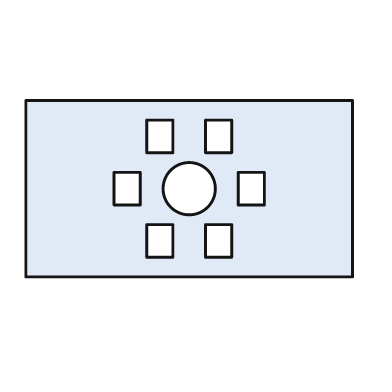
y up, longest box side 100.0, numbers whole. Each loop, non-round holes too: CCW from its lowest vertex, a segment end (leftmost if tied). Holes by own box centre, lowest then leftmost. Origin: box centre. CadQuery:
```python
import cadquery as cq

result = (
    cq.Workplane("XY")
    .moveTo(-50.0, -27.0)
    .lineTo(50.0, -27.0)
    .lineTo(50.0, 27.0)
    .lineTo(-50.0, 27.0)
    .close()
    .moveTo(-13.0, -21.0)
    .lineTo(-5.0, -21.0)
    .lineTo(-5.0, -11.0)
    .lineTo(-13.0, -11.0)
    .close()
    .moveTo(5.0, -21.0)
    .lineTo(13.0, -21.0)
    .lineTo(13.0, -11.0)
    .lineTo(5.0, -11.0)
    .close()
    .moveTo(-23.0, -5.0)
    .lineTo(-15.0, -5.0)
    .lineTo(-15.0, 5.0)
    .lineTo(-23.0, 5.0)
    .close()
    .moveTo(0.0, 0.0)
    .circle(8.0)
    .moveTo(15.0, -5.0)
    .lineTo(23.0, -5.0)
    .lineTo(23.0, 5.0)
    .lineTo(15.0, 5.0)
    .close()
    .moveTo(-13.0, 11.0)
    .lineTo(-5.0, 11.0)
    .lineTo(-5.0, 21.0)
    .lineTo(-13.0, 21.0)
    .close()
    .moveTo(5.0, 11.0)
    .lineTo(13.0, 11.0)
    .lineTo(13.0, 21.0)
    .lineTo(5.0, 21.0)
    .close()
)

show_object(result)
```